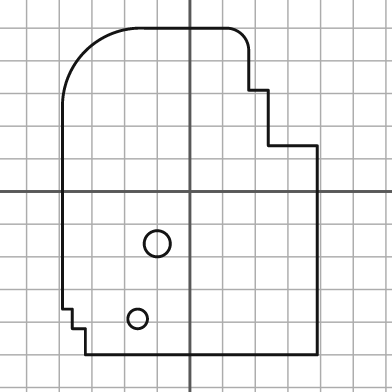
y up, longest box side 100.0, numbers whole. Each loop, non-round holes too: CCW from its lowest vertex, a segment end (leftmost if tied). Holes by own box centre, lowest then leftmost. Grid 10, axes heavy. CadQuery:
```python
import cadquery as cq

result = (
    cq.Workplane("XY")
    .moveTo(-32.0, -50.0)
    .lineTo(39.0, -50.0)
    .lineTo(39.0, 14.0)
    .lineTo(24.0, 14.0)
    .lineTo(24.0, 31.0)
    .lineTo(18.0, 31.0)
    .lineTo(18.0, 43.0)
    .threePointArc((16.0, 48.0), (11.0, 50.0))
    .lineTo(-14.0, 50.0)
    .threePointArc((-32.0, 43.0), (-39.0, 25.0))
    .lineTo(-39.0, -36.0)
    .lineTo(-36.0, -36.0)
    .lineTo(-36.0, -42.0)
    .lineTo(-32.0, -42.0)
    .close()
    .moveTo(-16.0, -39.0)
    .circle(3.0)
    .moveTo(-10.0, -16.0)
    .circle(4.0)
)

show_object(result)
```